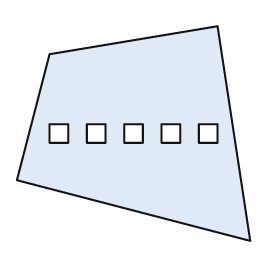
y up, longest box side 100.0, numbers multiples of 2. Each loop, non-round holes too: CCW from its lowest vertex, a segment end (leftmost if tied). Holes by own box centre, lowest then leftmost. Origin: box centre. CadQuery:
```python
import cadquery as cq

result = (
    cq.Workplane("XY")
    .moveTo(50.0, -46.0)
    .lineTo(36.0, 46.0)
    .lineTo(-36.0, 34.0)
    .lineTo(-50.0, -20.0)
    .close()
    .moveTo(-36.0, -4.0)
    .lineTo(-28.0, -4.0)
    .lineTo(-28.0, 4.0)
    .lineTo(-36.0, 4.0)
    .close()
    .moveTo(-20.0, -4.0)
    .lineTo(-12.0, -4.0)
    .lineTo(-12.0, 4.0)
    .lineTo(-20.0, 4.0)
    .close()
    .moveTo(-4.0, -4.0)
    .lineTo(4.0, -4.0)
    .lineTo(4.0, 4.0)
    .lineTo(-4.0, 4.0)
    .close()
    .moveTo(12.0, -4.0)
    .lineTo(20.0, -4.0)
    .lineTo(20.0, 4.0)
    .lineTo(12.0, 4.0)
    .close()
    .moveTo(28.0, -4.0)
    .lineTo(36.0, -4.0)
    .lineTo(36.0, 4.0)
    .lineTo(28.0, 4.0)
    .close()
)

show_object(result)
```